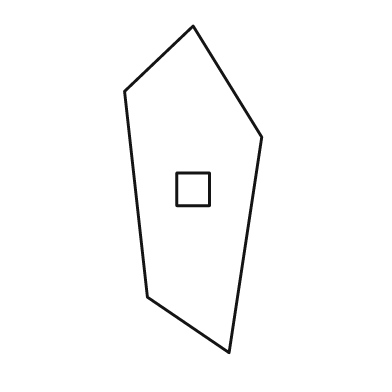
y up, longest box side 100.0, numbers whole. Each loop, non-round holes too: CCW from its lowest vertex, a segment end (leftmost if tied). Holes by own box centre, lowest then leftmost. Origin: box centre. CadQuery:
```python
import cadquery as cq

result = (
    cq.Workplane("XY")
    .moveTo(11.0, -50.0)
    .lineTo(21.0, 16.0)
    .lineTo(0.0, 50.0)
    .lineTo(-21.0, 30.0)
    .lineTo(-14.0, -33.0)
    .close()
    .moveTo(-5.0, -5.0)
    .lineTo(5.0, -5.0)
    .lineTo(5.0, 5.0)
    .lineTo(-5.0, 5.0)
    .close()
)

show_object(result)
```